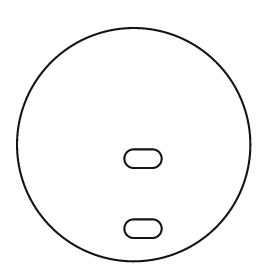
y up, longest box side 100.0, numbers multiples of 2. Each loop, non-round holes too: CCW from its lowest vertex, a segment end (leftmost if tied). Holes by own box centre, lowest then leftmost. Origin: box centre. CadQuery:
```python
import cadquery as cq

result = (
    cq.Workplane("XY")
    .moveTo(0.0, 0.0)
    .circle(50.0)
    .moveTo(0.0, -40.0)
    .lineTo(8.0, -40.0)
    .threePointArc((12.0, -36.0), (8.0, -32.0))
    .lineTo(0.0, -32.0)
    .threePointArc((-4.0, -36.0), (0.0, -40.0))
    .close()
    .moveTo(0.0, -10.0)
    .lineTo(8.0, -10.0)
    .threePointArc((12.0, -6.0), (8.0, -2.0))
    .lineTo(0.0, -2.0)
    .threePointArc((-4.0, -6.0), (0.0, -10.0))
    .close()
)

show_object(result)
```